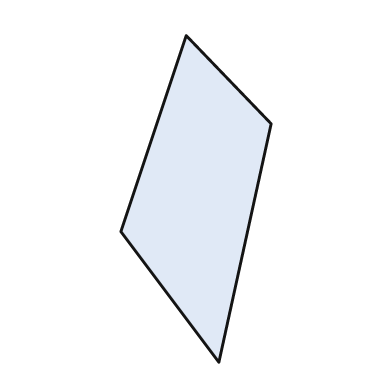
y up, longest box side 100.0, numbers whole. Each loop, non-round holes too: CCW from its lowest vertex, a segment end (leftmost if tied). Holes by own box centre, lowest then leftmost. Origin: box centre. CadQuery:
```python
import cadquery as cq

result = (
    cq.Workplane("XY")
    .moveTo(7.0, -50.0)
    .lineTo(23.0, 23.0)
    .lineTo(-3.0, 50.0)
    .lineTo(-23.0, -10.0)
    .close()
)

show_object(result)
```